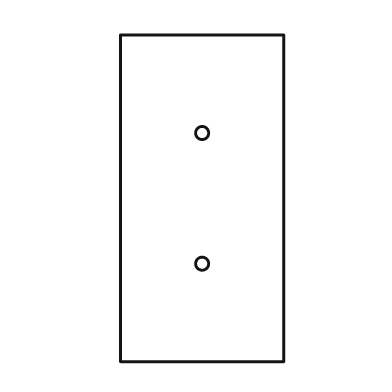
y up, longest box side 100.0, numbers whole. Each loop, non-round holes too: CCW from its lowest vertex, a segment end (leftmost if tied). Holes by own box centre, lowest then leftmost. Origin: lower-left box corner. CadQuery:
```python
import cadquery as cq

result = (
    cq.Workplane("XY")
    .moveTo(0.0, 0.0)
    .lineTo(50.0, 0.0)
    .lineTo(50.0, 100.0)
    .lineTo(0.0, 100.0)
    .close()
    .moveTo(25.0, 30.0)
    .circle(2.0)
    .moveTo(25.0, 70.0)
    .circle(2.0)
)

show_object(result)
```